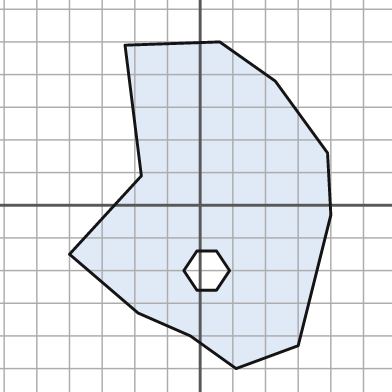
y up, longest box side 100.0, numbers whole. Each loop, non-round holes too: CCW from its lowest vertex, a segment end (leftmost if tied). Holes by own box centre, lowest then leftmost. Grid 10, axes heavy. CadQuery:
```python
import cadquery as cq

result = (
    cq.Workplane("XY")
    .moveTo(11.0, -50.0)
    .lineTo(30.0, -43.0)
    .lineTo(40.0, -3.0)
    .lineTo(39.0, 16.0)
    .lineTo(23.0, 38.0)
    .lineTo(6.0, 50.0)
    .lineTo(-23.0, 49.0)
    .lineTo(-18.0, 9.0)
    .lineTo(-40.0, -15.0)
    .lineTo(-19.0, -33.0)
    .lineTo(-3.0, -40.0)
    .close()
    .moveTo(-1.0, -26.0)
    .lineTo(5.0, -26.0)
    .lineTo(9.0, -20.0)
    .lineTo(5.0, -14.0)
    .lineTo(-1.0, -14.0)
    .lineTo(-5.0, -20.0)
    .close()
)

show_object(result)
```